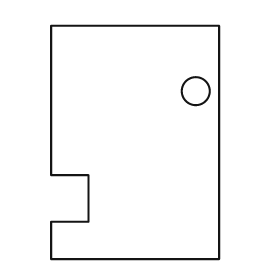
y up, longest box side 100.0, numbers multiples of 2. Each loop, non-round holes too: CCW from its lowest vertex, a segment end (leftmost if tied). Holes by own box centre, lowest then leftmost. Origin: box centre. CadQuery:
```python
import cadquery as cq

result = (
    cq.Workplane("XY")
    .moveTo(-36.0, -50.0)
    .lineTo(36.0, -50.0)
    .lineTo(36.0, 50.0)
    .lineTo(-36.0, 50.0)
    .lineTo(-36.0, -14.0)
    .lineTo(-20.0, -14.0)
    .lineTo(-20.0, -34.0)
    .lineTo(-36.0, -34.0)
    .close()
    .moveTo(26.0, 22.0)
    .circle(6.0)
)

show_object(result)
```